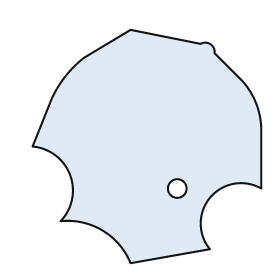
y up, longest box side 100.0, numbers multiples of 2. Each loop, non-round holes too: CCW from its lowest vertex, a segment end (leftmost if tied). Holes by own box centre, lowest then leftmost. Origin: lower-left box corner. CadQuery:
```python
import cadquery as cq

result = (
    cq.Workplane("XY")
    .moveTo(42.0, 0.0)
    .lineTo(76.0, 6.0)
    .threePointArc((76.0, 28.0), (98.0, 32.0))
    .lineTo(98.0, 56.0)
    .threePointArc((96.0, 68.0), (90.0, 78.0))
    .lineTo(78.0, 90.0)
    .threePointArc((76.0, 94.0), (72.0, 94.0))
    .lineTo(42.0, 100.0)
    .lineTo(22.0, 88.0)
    .threePointArc((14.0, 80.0), (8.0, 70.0))
    .lineTo(0.0, 50.0)
    .threePointArc((16.0, 38.0), (12.0, 18.0))
    .threePointArc((30.0, 14.0), (42.0, 0.0))
    .close()
    .moveTo(62.0, 32.0)
    .circle(4.0)
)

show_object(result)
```